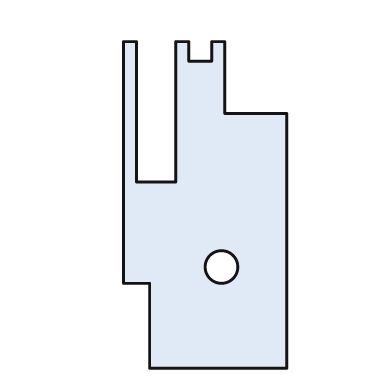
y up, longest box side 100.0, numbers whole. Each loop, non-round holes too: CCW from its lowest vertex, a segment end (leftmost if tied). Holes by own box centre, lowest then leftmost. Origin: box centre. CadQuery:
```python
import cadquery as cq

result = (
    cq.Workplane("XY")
    .moveTo(-17.0, -50.0)
    .lineTo(25.0, -50.0)
    .lineTo(25.0, 28.0)
    .lineTo(6.0, 28.0)
    .lineTo(6.0, 50.0)
    .lineTo(2.0, 50.0)
    .lineTo(2.0, 44.0)
    .lineTo(-5.0, 44.0)
    .lineTo(-5.0, 50.0)
    .lineTo(-9.0, 50.0)
    .lineTo(-9.0, 7.0)
    .lineTo(-21.0, 7.0)
    .lineTo(-21.0, 50.0)
    .lineTo(-25.0, 50.0)
    .lineTo(-25.0, -24.0)
    .lineTo(-17.0, -24.0)
    .close()
    .moveTo(5.0, -19.0)
    .circle(5.0)
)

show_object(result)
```